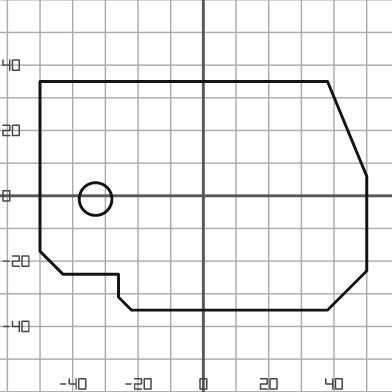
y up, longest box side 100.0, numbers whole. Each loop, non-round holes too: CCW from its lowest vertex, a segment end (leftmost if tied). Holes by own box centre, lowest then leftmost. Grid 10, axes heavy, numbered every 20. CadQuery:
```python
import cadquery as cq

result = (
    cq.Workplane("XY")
    .moveTo(-22.0, -35.0)
    .lineTo(38.0, -35.0)
    .lineTo(50.0, -23.0)
    .lineTo(50.0, 6.0)
    .lineTo(38.0, 35.0)
    .lineTo(-50.0, 35.0)
    .lineTo(-50.0, -17.0)
    .lineTo(-43.0, -24.0)
    .lineTo(-26.0, -24.0)
    .lineTo(-26.0, -31.0)
    .close()
    .moveTo(-33.0, -1.0)
    .circle(5.0)
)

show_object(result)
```